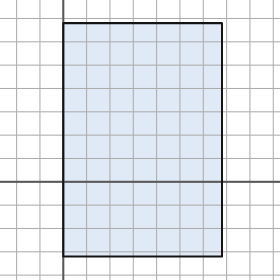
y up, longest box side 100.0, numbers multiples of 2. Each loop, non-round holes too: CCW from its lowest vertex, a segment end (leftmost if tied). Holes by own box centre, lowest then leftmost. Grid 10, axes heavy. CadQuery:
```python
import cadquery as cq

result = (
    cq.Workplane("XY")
    .moveTo(0.0, -32.0)
    .lineTo(68.0, -32.0)
    .lineTo(68.0, 68.0)
    .lineTo(0.0, 68.0)
    .close()
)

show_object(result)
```